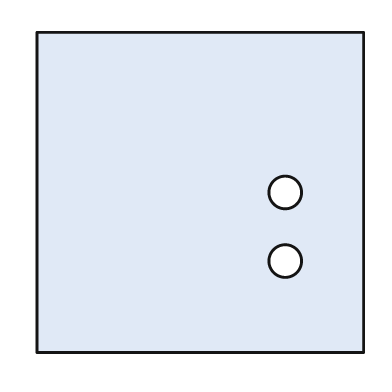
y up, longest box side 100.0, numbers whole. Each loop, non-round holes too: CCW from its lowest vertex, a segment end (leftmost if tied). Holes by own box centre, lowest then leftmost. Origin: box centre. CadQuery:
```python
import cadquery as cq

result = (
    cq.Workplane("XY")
    .moveTo(-50.0, -49.0)
    .lineTo(50.0, -49.0)
    .lineTo(50.0, 49.0)
    .lineTo(-50.0, 49.0)
    .close()
    .moveTo(26.0, -21.0)
    .circle(5.0)
    .moveTo(26.0, 0.0)
    .circle(5.0)
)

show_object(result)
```